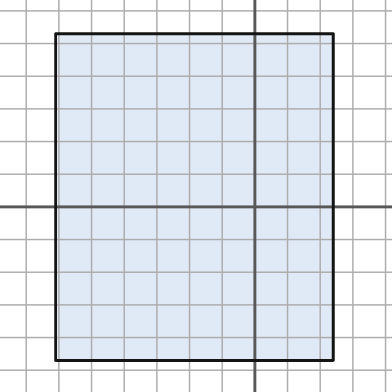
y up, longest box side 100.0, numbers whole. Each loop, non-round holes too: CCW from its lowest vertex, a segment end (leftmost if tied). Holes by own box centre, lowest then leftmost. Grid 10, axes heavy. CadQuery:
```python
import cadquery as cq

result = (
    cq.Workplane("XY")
    .moveTo(-61.0, -47.0)
    .lineTo(24.0, -47.0)
    .lineTo(24.0, 53.0)
    .lineTo(-61.0, 53.0)
    .close()
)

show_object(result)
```